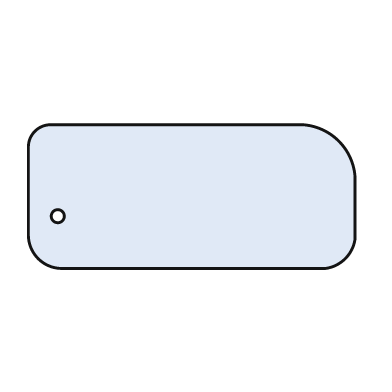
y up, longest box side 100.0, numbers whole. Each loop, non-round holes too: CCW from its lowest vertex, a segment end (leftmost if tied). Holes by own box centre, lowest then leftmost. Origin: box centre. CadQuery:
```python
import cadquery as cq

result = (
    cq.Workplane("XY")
    .moveTo(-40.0, -22.0)
    .lineTo(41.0, -22.0)
    .threePointArc((47.0, -19.0), (50.0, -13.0))
    .lineTo(50.0, 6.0)
    .threePointArc((45.0, 17.0), (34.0, 22.0))
    .lineTo(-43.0, 22.0)
    .threePointArc((-48.0, 20.0), (-50.0, 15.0))
    .lineTo(-50.0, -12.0)
    .threePointArc((-47.0, -19.0), (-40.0, -22.0))
    .close()
    .moveTo(-41.0, -6.0)
    .circle(2.0)
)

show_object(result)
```